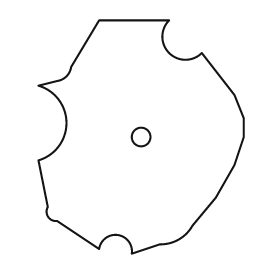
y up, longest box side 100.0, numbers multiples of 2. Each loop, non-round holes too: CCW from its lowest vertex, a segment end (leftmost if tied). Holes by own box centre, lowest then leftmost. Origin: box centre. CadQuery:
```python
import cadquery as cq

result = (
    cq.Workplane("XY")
    .moveTo(-4.0, -50.0)
    .lineTo(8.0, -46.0)
    .threePointArc((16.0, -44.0), (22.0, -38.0))
    .lineTo(32.0, -26.0)
    .lineTo(40.0, -12.0)
    .lineTo(44.0, 0.0)
    .lineTo(44.0, 8.0)
    .lineTo(40.0, 18.0)
    .lineTo(26.0, 36.0)
    .threePointArc((12.0, 36.0), (12.0, 50.0))
    .lineTo(-18.0, 50.0)
    .lineTo(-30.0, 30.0)
    .threePointArc((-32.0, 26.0), (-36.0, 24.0))
    .lineTo(-44.0, 22.0)
    .threePointArc((-32.0, 6.0), (-44.0, -10.0))
    .lineTo(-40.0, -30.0)
    .threePointArc((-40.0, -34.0), (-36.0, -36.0))
    .lineTo(-18.0, -48.0)
    .threePointArc((-10.0, -42.0), (-4.0, -50.0))
    .close()
    .moveTo(0.0, 0.0)
    .circle(4.0)
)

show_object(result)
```